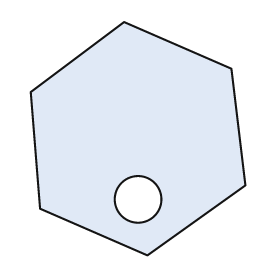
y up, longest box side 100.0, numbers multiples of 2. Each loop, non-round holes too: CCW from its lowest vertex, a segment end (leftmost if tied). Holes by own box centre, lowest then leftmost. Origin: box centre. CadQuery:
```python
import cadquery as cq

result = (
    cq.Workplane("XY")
    .moveTo(4.0, -50.0)
    .lineTo(46.0, -20.0)
    .lineTo(40.0, 30.0)
    .lineTo(-6.0, 50.0)
    .lineTo(-46.0, 20.0)
    .lineTo(-42.0, -30.0)
    .close()
    .moveTo(0.0, -26.0)
    .circle(10.0)
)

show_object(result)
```